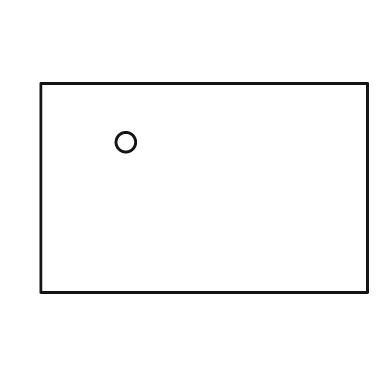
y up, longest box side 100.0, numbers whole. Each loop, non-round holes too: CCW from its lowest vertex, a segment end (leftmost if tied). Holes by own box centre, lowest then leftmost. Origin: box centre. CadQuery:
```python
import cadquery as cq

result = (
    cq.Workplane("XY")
    .moveTo(-50.0, -32.0)
    .lineTo(50.0, -32.0)
    .lineTo(50.0, 32.0)
    .lineTo(-50.0, 32.0)
    .close()
    .moveTo(-24.0, 14.0)
    .circle(3.0)
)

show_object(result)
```